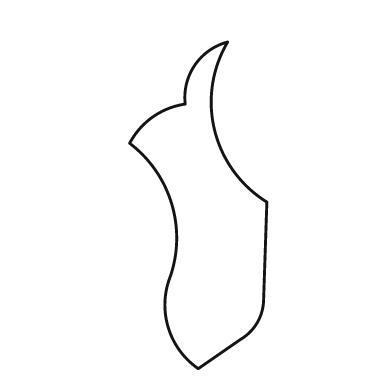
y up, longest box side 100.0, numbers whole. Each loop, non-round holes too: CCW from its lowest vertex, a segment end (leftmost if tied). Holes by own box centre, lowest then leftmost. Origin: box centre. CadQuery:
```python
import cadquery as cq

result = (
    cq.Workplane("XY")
    .moveTo(0.0, -50.0)
    .lineTo(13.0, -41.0)
    .threePointArc((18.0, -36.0), (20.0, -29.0))
    .lineTo(21.0, 1.0)
    .threePointArc((5.0, 23.0), (9.0, 50.0))
    .threePointArc((-1.0, 43.0), (-4.0, 31.0))
    .threePointArc((-14.0, 27.0), (-21.0, 19.0))
    .threePointArc((-8.0, 0.0), (-9.0, -23.0))
    .threePointArc((-9.0, -38.0), (0.0, -50.0))
    .close()
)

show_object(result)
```